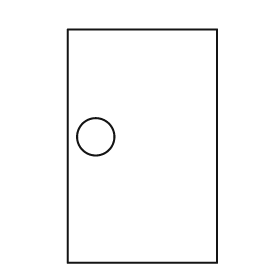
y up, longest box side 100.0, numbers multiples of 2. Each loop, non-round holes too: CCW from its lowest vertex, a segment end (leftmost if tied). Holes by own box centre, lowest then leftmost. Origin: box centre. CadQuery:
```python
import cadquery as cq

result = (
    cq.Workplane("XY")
    .moveTo(-32.0, -50.0)
    .lineTo(32.0, -50.0)
    .lineTo(32.0, 50.0)
    .lineTo(-32.0, 50.0)
    .close()
    .moveTo(-20.0, 4.0)
    .circle(8.0)
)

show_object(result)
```